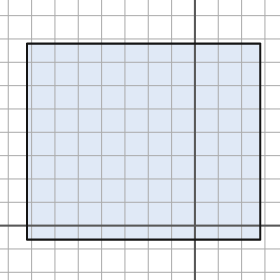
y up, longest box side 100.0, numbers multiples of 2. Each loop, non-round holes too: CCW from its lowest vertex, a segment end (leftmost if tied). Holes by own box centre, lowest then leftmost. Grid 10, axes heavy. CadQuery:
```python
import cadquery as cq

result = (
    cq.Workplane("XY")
    .moveTo(-72.0, -6.0)
    .lineTo(28.0, -6.0)
    .lineTo(28.0, 78.0)
    .lineTo(-72.0, 78.0)
    .close()
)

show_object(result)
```